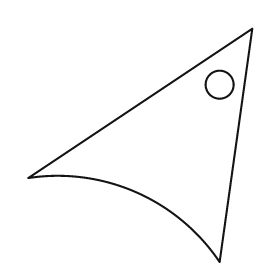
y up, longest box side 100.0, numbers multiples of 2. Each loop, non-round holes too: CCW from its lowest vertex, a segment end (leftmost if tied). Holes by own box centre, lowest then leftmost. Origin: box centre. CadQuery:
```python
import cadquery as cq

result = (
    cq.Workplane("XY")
    .moveTo(34.0, -50.0)
    .lineTo(48.0, 50.0)
    .lineTo(-48.0, -14.0)
    .threePointArc((-2.0, -20.0), (34.0, -50.0))
    .close()
    .moveTo(34.0, 26.0)
    .circle(6.0)
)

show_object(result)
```